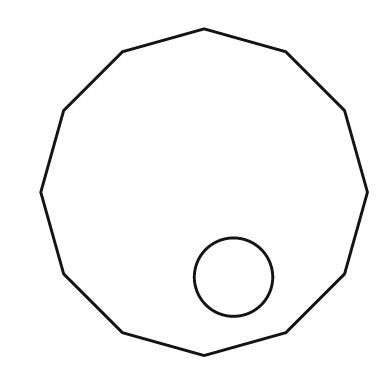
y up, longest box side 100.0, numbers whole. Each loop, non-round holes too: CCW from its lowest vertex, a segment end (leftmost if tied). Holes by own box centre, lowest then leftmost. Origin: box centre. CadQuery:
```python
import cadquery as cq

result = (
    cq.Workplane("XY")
    .moveTo(0.0, -50.0)
    .lineTo(25.0, -43.0)
    .lineTo(43.0, -25.0)
    .lineTo(50.0, 0.0)
    .lineTo(43.0, 25.0)
    .lineTo(25.0, 43.0)
    .lineTo(0.0, 50.0)
    .lineTo(-25.0, 43.0)
    .lineTo(-43.0, 25.0)
    .lineTo(-50.0, 0.0)
    .lineTo(-43.0, -25.0)
    .lineTo(-25.0, -43.0)
    .close()
    .moveTo(9.0, -26.0)
    .circle(12.0)
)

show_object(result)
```